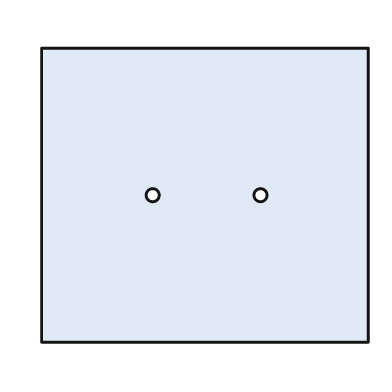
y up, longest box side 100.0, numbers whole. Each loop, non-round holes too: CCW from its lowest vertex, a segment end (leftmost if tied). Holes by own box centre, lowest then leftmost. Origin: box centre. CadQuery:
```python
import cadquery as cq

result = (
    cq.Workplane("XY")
    .moveTo(-50.0, -45.0)
    .lineTo(50.0, -45.0)
    .lineTo(50.0, 45.0)
    .lineTo(-50.0, 45.0)
    .close()
    .moveTo(-16.0, 0.0)
    .circle(2.0)
    .moveTo(17.0, 0.0)
    .circle(2.0)
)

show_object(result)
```